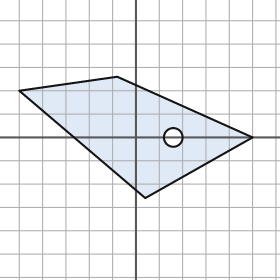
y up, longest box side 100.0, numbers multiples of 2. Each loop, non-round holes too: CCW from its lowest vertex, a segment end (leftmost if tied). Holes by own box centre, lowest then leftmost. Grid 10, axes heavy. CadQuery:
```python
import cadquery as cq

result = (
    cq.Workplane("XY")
    .moveTo(4.0, -26.0)
    .lineTo(50.0, 0.0)
    .lineTo(-8.0, 26.0)
    .lineTo(-50.0, 20.0)
    .close()
    .moveTo(16.0, 0.0)
    .circle(4.0)
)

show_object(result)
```